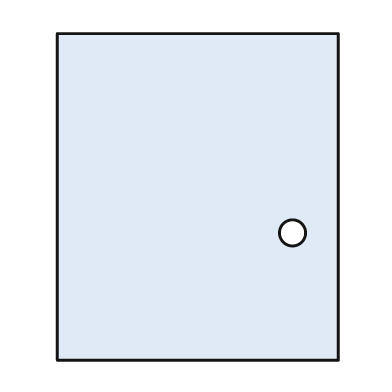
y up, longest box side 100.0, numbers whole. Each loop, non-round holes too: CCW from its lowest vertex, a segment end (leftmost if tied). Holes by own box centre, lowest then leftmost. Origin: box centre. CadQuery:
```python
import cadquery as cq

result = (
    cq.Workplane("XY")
    .moveTo(-43.0, -50.0)
    .lineTo(43.0, -50.0)
    .lineTo(43.0, 50.0)
    .lineTo(-43.0, 50.0)
    .close()
    .moveTo(29.0, -11.0)
    .circle(4.0)
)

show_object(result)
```